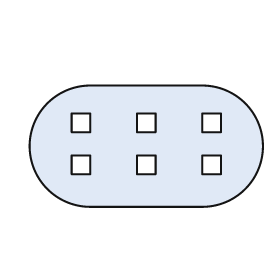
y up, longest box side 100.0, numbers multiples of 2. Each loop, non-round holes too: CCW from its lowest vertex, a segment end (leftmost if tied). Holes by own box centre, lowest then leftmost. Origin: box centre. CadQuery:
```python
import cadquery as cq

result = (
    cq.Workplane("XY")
    .moveTo(-24.0, -26.0)
    .lineTo(24.0, -26.0)
    .threePointArc((50.0, 0.0), (24.0, 26.0))
    .lineTo(-24.0, 26.0)
    .threePointArc((-50.0, 0.0), (-24.0, -26.0))
    .close()
    .moveTo(-32.0, -12.0)
    .lineTo(-24.0, -12.0)
    .lineTo(-24.0, -4.0)
    .lineTo(-32.0, -4.0)
    .close()
    .moveTo(-4.0, -12.0)
    .lineTo(4.0, -12.0)
    .lineTo(4.0, -4.0)
    .lineTo(-4.0, -4.0)
    .close()
    .moveTo(24.0, -12.0)
    .lineTo(32.0, -12.0)
    .lineTo(32.0, -4.0)
    .lineTo(24.0, -4.0)
    .close()
    .moveTo(-32.0, 6.0)
    .lineTo(-24.0, 6.0)
    .lineTo(-24.0, 14.0)
    .lineTo(-32.0, 14.0)
    .close()
    .moveTo(-4.0, 6.0)
    .lineTo(4.0, 6.0)
    .lineTo(4.0, 14.0)
    .lineTo(-4.0, 14.0)
    .close()
    .moveTo(24.0, 6.0)
    .lineTo(32.0, 6.0)
    .lineTo(32.0, 14.0)
    .lineTo(24.0, 14.0)
    .close()
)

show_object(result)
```